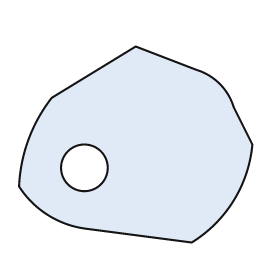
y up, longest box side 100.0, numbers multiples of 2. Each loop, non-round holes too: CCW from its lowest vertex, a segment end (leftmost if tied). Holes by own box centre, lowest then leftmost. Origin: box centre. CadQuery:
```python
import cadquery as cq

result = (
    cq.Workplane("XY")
    .moveTo(24.0, -42.0)
    .threePointArc((42.0, -24.0), (50.0, 0.0))
    .lineTo(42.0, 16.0)
    .threePointArc((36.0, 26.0), (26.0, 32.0))
    .lineTo(0.0, 42.0)
    .lineTo(-36.0, 20.0)
    .threePointArc((-46.0, 2.0), (-50.0, -18.0))
    .threePointArc((-38.0, -30.0), (-22.0, -36.0))
    .close()
    .moveTo(-22.0, -10.0)
    .circle(10.0)
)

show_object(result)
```